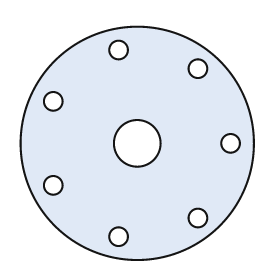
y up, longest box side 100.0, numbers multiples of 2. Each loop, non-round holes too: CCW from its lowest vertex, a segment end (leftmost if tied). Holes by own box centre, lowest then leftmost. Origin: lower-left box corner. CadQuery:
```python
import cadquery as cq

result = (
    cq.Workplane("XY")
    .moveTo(50.0, 50.0)
    .circle(50.0)
    .moveTo(42.0, 10.0)
    .circle(4.0)
    .moveTo(76.0, 18.0)
    .circle(4.0)
    .moveTo(14.0, 32.0)
    .circle(4.0)
    .moveTo(50.0, 50.0)
    .circle(10.0)
    .moveTo(90.0, 50.0)
    .circle(4.0)
    .moveTo(14.0, 68.0)
    .circle(4.0)
    .moveTo(76.0, 82.0)
    .circle(4.0)
    .moveTo(42.0, 90.0)
    .circle(4.0)
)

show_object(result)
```